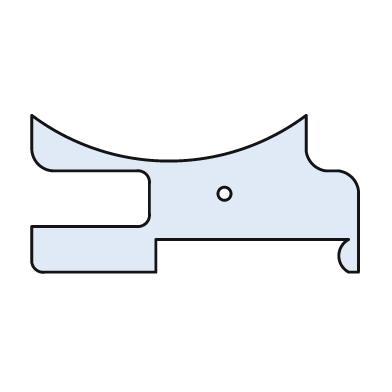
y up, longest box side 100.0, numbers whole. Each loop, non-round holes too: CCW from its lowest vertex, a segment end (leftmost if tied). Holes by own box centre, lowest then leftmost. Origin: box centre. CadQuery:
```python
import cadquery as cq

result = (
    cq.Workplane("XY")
    .moveTo(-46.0, -24.0)
    .lineTo(-12.0, -24.0)
    .lineTo(-12.0, -14.0)
    .lineTo(47.0, -14.0)
    .threePointArc((44.0, -19.0), (47.0, -24.0))
    .lineTo(50.0, -24.0)
    .lineTo(50.0, 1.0)
    .threePointArc((48.0, 5.0), (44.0, 7.0))
    .lineTo(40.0, 7.0)
    .threePointArc((36.0, 9.0), (34.0, 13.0))
    .lineTo(34.0, 24.0)
    .threePointArc((-8.0, 10.0), (-50.0, 24.0))
    .lineTo(-50.0, 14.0)
    .threePointArc((-48.0, 9.0), (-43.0, 7.0))
    .lineTo(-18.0, 7.0)
    .threePointArc((-15.0, 6.0), (-14.0, 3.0))
    .lineTo(-14.0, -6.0)
    .threePointArc((-15.0, -9.0), (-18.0, -10.0))
    .lineTo(-50.0, -10.0)
    .lineTo(-50.0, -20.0)
    .threePointArc((-49.0, -23.0), (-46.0, -24.0))
    .close()
    .moveTo(9.0, 0.0)
    .circle(2.0)
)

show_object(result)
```